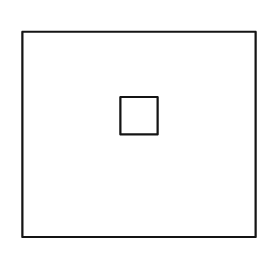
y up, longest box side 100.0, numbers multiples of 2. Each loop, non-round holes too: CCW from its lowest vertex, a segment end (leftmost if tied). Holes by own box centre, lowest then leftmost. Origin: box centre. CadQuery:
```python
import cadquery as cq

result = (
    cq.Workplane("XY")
    .moveTo(-50.0, -44.0)
    .lineTo(50.0, -44.0)
    .lineTo(50.0, 44.0)
    .lineTo(-50.0, 44.0)
    .close()
    .moveTo(-8.0, 0.0)
    .lineTo(8.0, 0.0)
    .lineTo(8.0, 16.0)
    .lineTo(-8.0, 16.0)
    .close()
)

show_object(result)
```